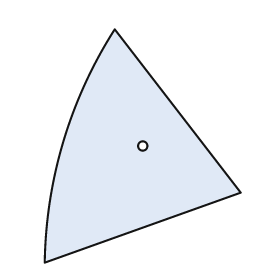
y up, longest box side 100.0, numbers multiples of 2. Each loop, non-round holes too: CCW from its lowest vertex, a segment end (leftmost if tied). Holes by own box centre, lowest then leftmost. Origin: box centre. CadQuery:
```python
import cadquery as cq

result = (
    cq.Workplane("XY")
    .moveTo(-42.0, -50.0)
    .lineTo(42.0, -20.0)
    .lineTo(-12.0, 50.0)
    .threePointArc((-34.0, 2.0), (-42.0, -50.0))
    .close()
    .moveTo(0.0, 0.0)
    .circle(2.0)
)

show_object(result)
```